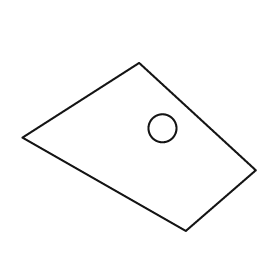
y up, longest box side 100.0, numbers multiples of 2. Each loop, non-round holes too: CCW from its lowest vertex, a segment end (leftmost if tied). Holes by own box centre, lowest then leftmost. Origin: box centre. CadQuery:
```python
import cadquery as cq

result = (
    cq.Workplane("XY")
    .moveTo(20.0, -36.0)
    .lineTo(50.0, -10.0)
    .lineTo(0.0, 36.0)
    .lineTo(-50.0, 4.0)
    .close()
    .moveTo(10.0, 8.0)
    .circle(6.0)
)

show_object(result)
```